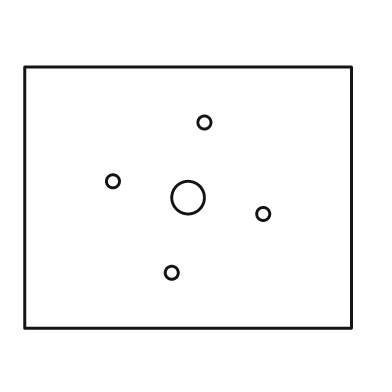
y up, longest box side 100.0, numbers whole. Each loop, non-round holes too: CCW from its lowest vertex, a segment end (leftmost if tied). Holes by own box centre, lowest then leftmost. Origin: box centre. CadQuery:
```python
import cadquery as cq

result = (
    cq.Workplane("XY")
    .moveTo(-50.0, -40.0)
    .lineTo(50.0, -40.0)
    .lineTo(50.0, 40.0)
    .lineTo(-50.0, 40.0)
    .close()
    .moveTo(-5.0, -23.0)
    .circle(2.0)
    .moveTo(23.0, -5.0)
    .circle(2.0)
    .moveTo(0.0, 0.0)
    .circle(5.0)
    .moveTo(-23.0, 5.0)
    .circle(2.0)
    .moveTo(5.0, 23.0)
    .circle(2.0)
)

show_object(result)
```